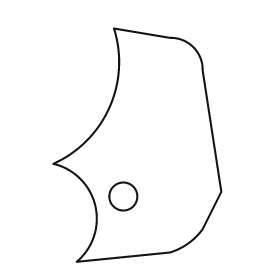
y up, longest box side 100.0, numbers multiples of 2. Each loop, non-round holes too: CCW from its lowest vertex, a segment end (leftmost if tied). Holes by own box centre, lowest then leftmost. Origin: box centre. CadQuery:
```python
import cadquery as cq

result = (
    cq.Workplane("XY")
    .moveTo(-26.0, -50.0)
    .lineTo(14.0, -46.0)
    .threePointArc((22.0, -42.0), (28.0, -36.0))
    .lineTo(36.0, -20.0)
    .lineTo(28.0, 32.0)
    .threePointArc((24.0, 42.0), (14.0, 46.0))
    .lineTo(-10.0, 50.0)
    .threePointArc((-12.0, 16.0), (-36.0, -8.0))
    .threePointArc((-18.0, -26.0), (-26.0, -50.0))
    .close()
    .moveTo(-6.0, -22.0)
    .circle(6.0)
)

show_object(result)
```